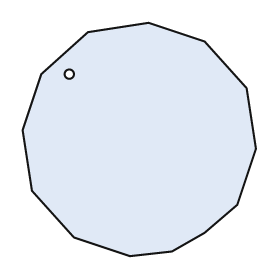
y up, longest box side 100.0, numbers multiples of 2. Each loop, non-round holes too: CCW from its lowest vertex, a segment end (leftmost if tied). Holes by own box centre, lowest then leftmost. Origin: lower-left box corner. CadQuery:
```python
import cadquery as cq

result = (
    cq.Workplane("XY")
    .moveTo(46.0, 0.0)
    .lineTo(64.0, 2.0)
    .lineTo(78.0, 10.0)
    .lineTo(92.0, 22.0)
    .lineTo(100.0, 46.0)
    .lineTo(96.0, 72.0)
    .lineTo(78.0, 92.0)
    .lineTo(54.0, 100.0)
    .lineTo(28.0, 96.0)
    .lineTo(8.0, 78.0)
    .lineTo(0.0, 54.0)
    .lineTo(4.0, 28.0)
    .lineTo(22.0, 8.0)
    .close()
    .moveTo(20.0, 78.0)
    .circle(2.0)
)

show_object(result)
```